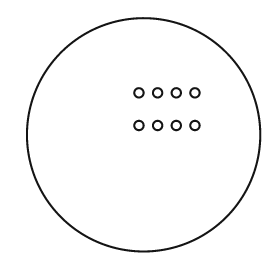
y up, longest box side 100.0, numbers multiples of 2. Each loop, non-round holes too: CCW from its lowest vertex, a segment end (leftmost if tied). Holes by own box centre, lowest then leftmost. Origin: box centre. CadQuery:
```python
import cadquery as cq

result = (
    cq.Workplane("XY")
    .moveTo(0.0, 0.0)
    .circle(50.0)
    .moveTo(-2.0, 4.0)
    .circle(2.0)
    .moveTo(6.0, 4.0)
    .circle(2.0)
    .moveTo(14.0, 4.0)
    .circle(2.0)
    .moveTo(22.0, 4.0)
    .circle(2.0)
    .moveTo(-2.0, 18.0)
    .circle(2.0)
    .moveTo(6.0, 18.0)
    .circle(2.0)
    .moveTo(14.0, 18.0)
    .circle(2.0)
    .moveTo(22.0, 18.0)
    .circle(2.0)
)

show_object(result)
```